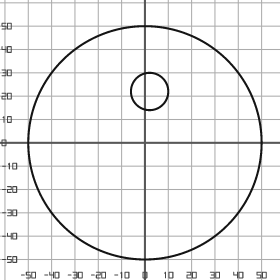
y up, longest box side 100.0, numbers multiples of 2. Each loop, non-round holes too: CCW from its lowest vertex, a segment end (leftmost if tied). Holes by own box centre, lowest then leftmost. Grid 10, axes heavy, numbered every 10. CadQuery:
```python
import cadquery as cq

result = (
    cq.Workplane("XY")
    .moveTo(0.0, 0.0)
    .circle(50.0)
    .moveTo(2.0, 22.0)
    .circle(8.0)
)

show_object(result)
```